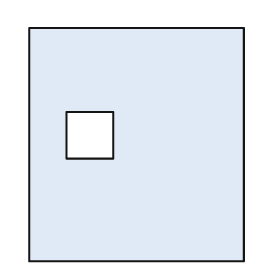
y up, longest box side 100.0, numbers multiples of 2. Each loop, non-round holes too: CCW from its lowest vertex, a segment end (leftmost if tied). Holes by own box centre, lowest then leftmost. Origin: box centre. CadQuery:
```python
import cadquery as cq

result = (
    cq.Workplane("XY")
    .moveTo(-46.0, -50.0)
    .lineTo(46.0, -50.0)
    .lineTo(46.0, 50.0)
    .lineTo(-46.0, 50.0)
    .close()
    .moveTo(-30.0, -6.0)
    .lineTo(-10.0, -6.0)
    .lineTo(-10.0, 14.0)
    .lineTo(-30.0, 14.0)
    .close()
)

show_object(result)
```